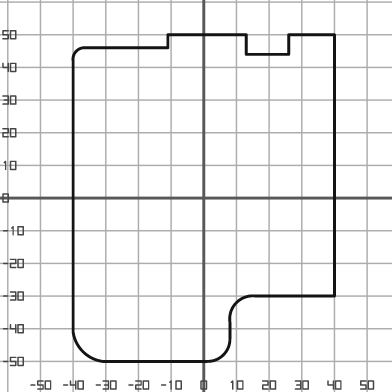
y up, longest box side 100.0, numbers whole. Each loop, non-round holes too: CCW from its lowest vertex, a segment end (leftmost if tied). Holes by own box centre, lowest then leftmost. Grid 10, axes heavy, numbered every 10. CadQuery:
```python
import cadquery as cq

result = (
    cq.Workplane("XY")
    .moveTo(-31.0, -50.0)
    .lineTo(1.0, -50.0)
    .threePointArc((6.0, -48.0), (8.0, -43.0))
    .lineTo(8.0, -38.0)
    .threePointArc((10.0, -32.0), (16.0, -30.0))
    .lineTo(40.0, -30.0)
    .lineTo(40.0, 50.0)
    .lineTo(26.0, 50.0)
    .lineTo(26.0, 44.0)
    .lineTo(13.0, 44.0)
    .lineTo(13.0, 50.0)
    .lineTo(-11.0, 50.0)
    .lineTo(-11.0, 46.0)
    .lineTo(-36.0, 46.0)
    .threePointArc((-39.0, 45.0), (-40.0, 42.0))
    .lineTo(-40.0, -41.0)
    .threePointArc((-37.0, -47.0), (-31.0, -50.0))
    .close()
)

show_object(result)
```